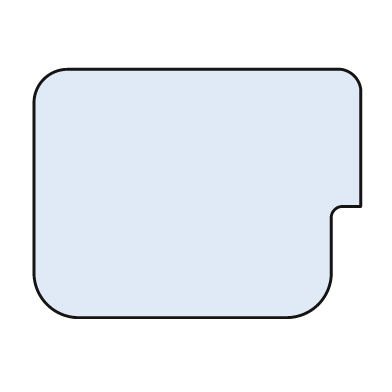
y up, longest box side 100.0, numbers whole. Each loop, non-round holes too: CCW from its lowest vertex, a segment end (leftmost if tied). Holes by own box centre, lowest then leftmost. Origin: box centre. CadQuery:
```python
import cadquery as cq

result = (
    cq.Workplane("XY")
    .moveTo(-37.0, -38.0)
    .lineTo(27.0, -38.0)
    .threePointArc((37.0, -34.0), (41.0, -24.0))
    .lineTo(41.0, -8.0)
    .threePointArc((42.0, -5.0), (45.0, -4.0))
    .lineTo(50.0, -4.0)
    .lineTo(50.0, 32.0)
    .threePointArc((48.0, 36.0), (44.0, 38.0))
    .lineTo(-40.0, 38.0)
    .threePointArc((-47.0, 35.0), (-50.0, 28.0))
    .lineTo(-50.0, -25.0)
    .threePointArc((-46.0, -34.0), (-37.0, -38.0))
    .close()
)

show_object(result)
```